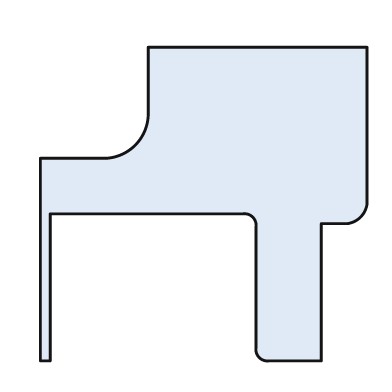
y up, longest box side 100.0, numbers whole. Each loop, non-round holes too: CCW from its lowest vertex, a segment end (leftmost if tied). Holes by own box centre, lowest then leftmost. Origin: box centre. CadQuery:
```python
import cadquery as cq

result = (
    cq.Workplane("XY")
    .moveTo(-50.0, -48.0)
    .lineTo(-47.0, -48.0)
    .lineTo(-47.0, -3.0)
    .lineTo(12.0, -3.0)
    .threePointArc((15.0, -4.0), (16.0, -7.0))
    .lineTo(16.0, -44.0)
    .threePointArc((17.0, -47.0), (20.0, -48.0))
    .lineTo(36.0, -48.0)
    .lineTo(36.0, -6.0)
    .lineTo(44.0, -6.0)
    .threePointArc((48.0, -4.0), (50.0, 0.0))
    .lineTo(50.0, 48.0)
    .lineTo(-17.0, 48.0)
    .lineTo(-17.0, 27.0)
    .threePointArc((-21.0, 18.0), (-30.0, 14.0))
    .lineTo(-50.0, 14.0)
    .close()
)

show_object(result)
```